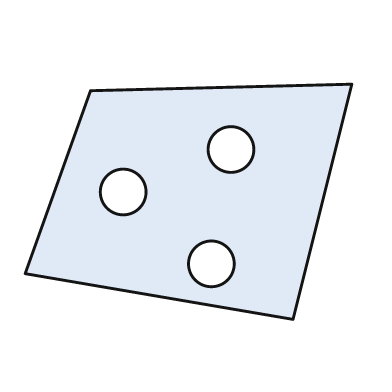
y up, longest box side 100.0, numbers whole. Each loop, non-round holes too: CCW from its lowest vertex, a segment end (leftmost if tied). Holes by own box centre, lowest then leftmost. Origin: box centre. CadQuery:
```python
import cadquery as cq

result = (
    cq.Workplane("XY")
    .moveTo(32.0, -36.0)
    .lineTo(50.0, 36.0)
    .lineTo(-30.0, 34.0)
    .lineTo(-50.0, -22.0)
    .close()
    .moveTo(7.0, -19.0)
    .circle(7.0)
    .moveTo(-20.0, 3.0)
    .circle(7.0)
    .moveTo(13.0, 16.0)
    .circle(7.0)
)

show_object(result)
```